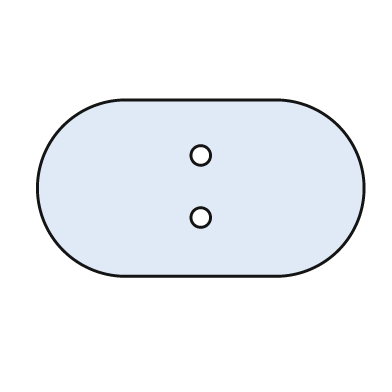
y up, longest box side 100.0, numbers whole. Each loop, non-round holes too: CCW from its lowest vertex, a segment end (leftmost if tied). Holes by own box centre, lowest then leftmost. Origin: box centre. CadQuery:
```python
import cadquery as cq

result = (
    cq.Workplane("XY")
    .moveTo(-23.0, -27.0)
    .lineTo(23.0, -27.0)
    .threePointArc((50.0, 0.0), (23.0, 27.0))
    .lineTo(-23.0, 27.0)
    .threePointArc((-50.0, 0.0), (-23.0, -27.0))
    .close()
    .moveTo(0.0, -9.0)
    .circle(3.0)
    .moveTo(0.0, 10.0)
    .circle(3.0)
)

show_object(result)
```